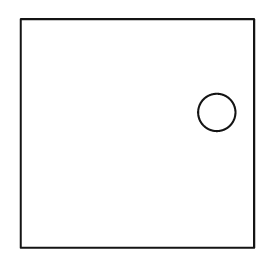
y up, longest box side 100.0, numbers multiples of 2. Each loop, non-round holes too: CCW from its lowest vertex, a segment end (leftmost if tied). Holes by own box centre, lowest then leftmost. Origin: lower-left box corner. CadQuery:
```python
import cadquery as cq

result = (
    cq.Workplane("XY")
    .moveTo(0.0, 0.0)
    .lineTo(100.0, 0.0)
    .lineTo(100.0, 98.0)
    .lineTo(0.0, 98.0)
    .close()
    .moveTo(84.0, 58.0)
    .circle(8.0)
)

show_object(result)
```